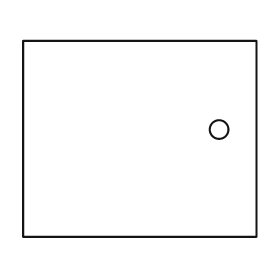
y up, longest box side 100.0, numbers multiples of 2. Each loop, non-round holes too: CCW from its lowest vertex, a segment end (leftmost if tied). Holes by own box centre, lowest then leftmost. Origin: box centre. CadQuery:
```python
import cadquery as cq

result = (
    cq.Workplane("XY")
    .moveTo(-50.0, -42.0)
    .lineTo(50.0, -42.0)
    .lineTo(50.0, 42.0)
    .lineTo(-50.0, 42.0)
    .close()
    .moveTo(34.0, 4.0)
    .circle(4.0)
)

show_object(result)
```